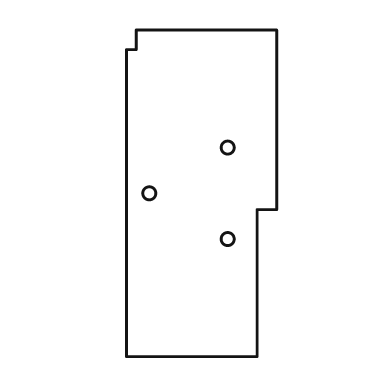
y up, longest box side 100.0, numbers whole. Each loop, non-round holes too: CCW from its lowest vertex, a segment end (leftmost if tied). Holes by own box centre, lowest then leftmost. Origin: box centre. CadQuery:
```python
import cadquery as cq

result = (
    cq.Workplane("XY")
    .moveTo(-23.0, -50.0)
    .lineTo(17.0, -50.0)
    .lineTo(17.0, -5.0)
    .lineTo(23.0, -5.0)
    .lineTo(23.0, 50.0)
    .lineTo(-20.0, 50.0)
    .lineTo(-20.0, 44.0)
    .lineTo(-23.0, 44.0)
    .close()
    .moveTo(8.0, -14.0)
    .circle(2.0)
    .moveTo(-16.0, 0.0)
    .circle(2.0)
    .moveTo(8.0, 14.0)
    .circle(2.0)
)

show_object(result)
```